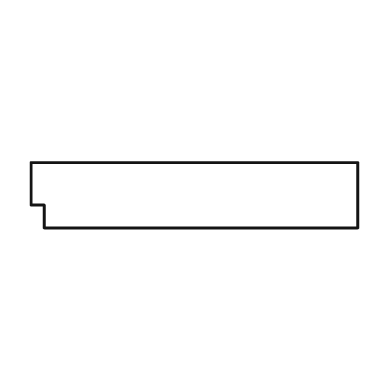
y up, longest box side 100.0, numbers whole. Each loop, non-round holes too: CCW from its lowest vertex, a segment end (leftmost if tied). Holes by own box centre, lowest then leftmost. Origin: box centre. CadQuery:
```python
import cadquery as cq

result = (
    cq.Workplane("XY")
    .moveTo(-46.0, -10.0)
    .lineTo(50.0, -10.0)
    .lineTo(50.0, 10.0)
    .lineTo(-50.0, 10.0)
    .lineTo(-50.0, -3.0)
    .lineTo(-46.0, -3.0)
    .close()
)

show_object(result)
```